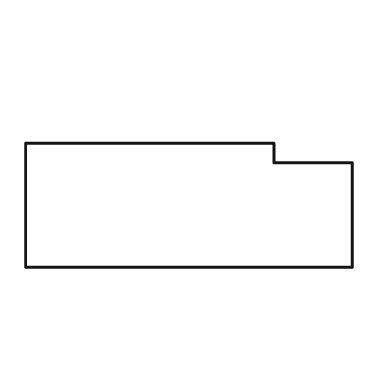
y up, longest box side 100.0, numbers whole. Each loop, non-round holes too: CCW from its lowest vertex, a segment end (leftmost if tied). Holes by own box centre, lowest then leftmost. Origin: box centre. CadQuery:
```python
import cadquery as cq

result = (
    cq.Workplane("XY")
    .moveTo(-50.0, -19.0)
    .lineTo(50.0, -19.0)
    .lineTo(50.0, 13.0)
    .lineTo(26.0, 13.0)
    .lineTo(26.0, 19.0)
    .lineTo(-50.0, 19.0)
    .close()
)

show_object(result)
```